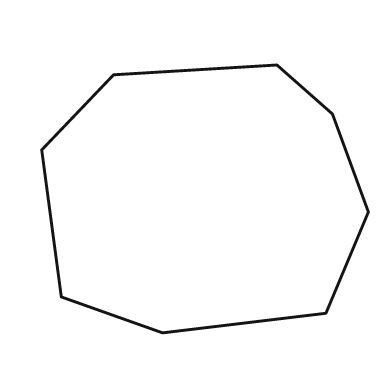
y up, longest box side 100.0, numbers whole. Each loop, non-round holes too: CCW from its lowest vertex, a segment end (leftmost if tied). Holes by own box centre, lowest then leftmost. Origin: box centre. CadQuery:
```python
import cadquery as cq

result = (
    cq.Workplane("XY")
    .moveTo(-13.0, -41.0)
    .lineTo(37.0, -35.0)
    .lineTo(50.0, -4.0)
    .lineTo(39.0, 26.0)
    .lineTo(22.0, 41.0)
    .lineTo(-28.0, 38.0)
    .lineTo(-50.0, 15.0)
    .lineTo(-44.0, -30.0)
    .close()
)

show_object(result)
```